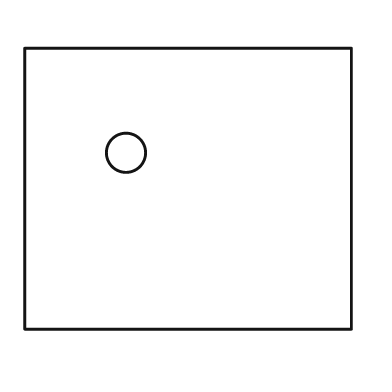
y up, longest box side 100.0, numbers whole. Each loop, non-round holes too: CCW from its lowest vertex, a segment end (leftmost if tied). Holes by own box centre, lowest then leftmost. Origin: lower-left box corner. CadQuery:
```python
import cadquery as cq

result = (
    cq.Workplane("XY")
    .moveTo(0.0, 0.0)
    .lineTo(100.0, 0.0)
    .lineTo(100.0, 86.0)
    .lineTo(0.0, 86.0)
    .close()
    .moveTo(31.0, 54.0)
    .circle(6.0)
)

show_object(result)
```